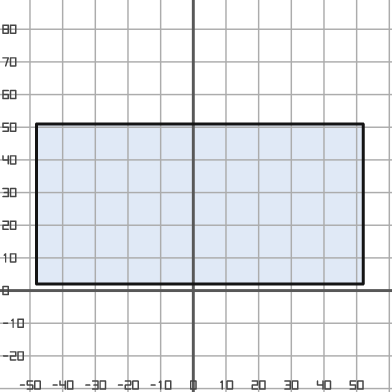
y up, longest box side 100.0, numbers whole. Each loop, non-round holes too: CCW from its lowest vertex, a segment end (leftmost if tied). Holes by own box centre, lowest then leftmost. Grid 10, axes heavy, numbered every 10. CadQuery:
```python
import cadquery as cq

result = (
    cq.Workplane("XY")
    .moveTo(-48.0, 2.0)
    .lineTo(52.0, 2.0)
    .lineTo(52.0, 51.0)
    .lineTo(-48.0, 51.0)
    .close()
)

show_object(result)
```